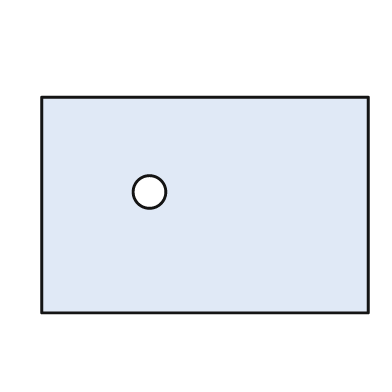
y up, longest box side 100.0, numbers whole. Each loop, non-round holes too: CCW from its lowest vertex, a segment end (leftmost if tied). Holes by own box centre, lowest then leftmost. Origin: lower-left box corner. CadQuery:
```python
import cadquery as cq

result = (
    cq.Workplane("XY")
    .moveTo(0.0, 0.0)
    .lineTo(100.0, 0.0)
    .lineTo(100.0, 66.0)
    .lineTo(0.0, 66.0)
    .close()
    .moveTo(33.0, 37.0)
    .circle(5.0)
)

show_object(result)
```